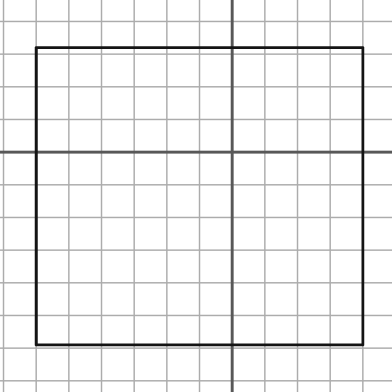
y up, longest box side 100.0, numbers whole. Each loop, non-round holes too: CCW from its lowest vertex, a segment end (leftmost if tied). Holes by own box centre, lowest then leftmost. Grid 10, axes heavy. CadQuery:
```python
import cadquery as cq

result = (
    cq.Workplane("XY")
    .moveTo(-60.0, -59.0)
    .lineTo(40.0, -59.0)
    .lineTo(40.0, 32.0)
    .lineTo(-60.0, 32.0)
    .close()
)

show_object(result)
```